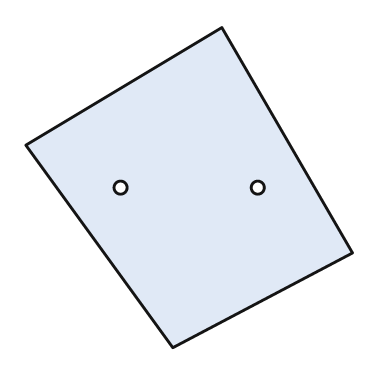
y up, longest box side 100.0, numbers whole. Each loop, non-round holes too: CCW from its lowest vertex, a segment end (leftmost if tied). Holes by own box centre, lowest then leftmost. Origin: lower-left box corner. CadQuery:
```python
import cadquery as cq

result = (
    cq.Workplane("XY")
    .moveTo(45.0, 0.0)
    .lineTo(100.0, 29.0)
    .lineTo(60.0, 98.0)
    .lineTo(0.0, 62.0)
    .close()
    .moveTo(29.0, 49.0)
    .circle(2.0)
    .moveTo(71.0, 49.0)
    .circle(2.0)
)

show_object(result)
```